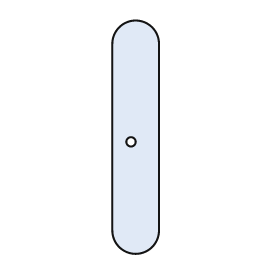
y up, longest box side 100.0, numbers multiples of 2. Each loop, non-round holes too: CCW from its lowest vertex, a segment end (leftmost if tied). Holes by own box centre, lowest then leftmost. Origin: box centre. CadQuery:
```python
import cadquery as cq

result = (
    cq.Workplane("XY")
    .moveTo(-10.0, -40.0)
    .threePointArc((0.0, -50.0), (10.0, -40.0))
    .lineTo(10.0, 40.0)
    .threePointArc((0.0, 50.0), (-10.0, 40.0))
    .close()
    .moveTo(-2.0, -2.0)
    .circle(2.0)
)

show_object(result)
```